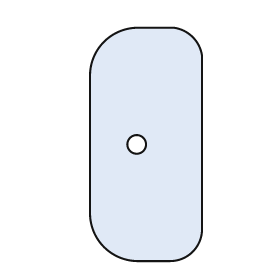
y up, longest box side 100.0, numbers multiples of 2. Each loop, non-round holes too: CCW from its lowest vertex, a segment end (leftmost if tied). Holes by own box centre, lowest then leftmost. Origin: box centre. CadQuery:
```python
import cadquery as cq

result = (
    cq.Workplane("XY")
    .moveTo(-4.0, -50.0)
    .lineTo(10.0, -50.0)
    .threePointArc((20.0, -46.0), (24.0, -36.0))
    .lineTo(24.0, 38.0)
    .threePointArc((20.0, 46.0), (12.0, 50.0))
    .lineTo(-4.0, 50.0)
    .threePointArc((-18.0, 44.0), (-24.0, 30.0))
    .lineTo(-24.0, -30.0)
    .threePointArc((-18.0, -44.0), (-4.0, -50.0))
    .close()
    .moveTo(-4.0, 0.0)
    .circle(4.0)
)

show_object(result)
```